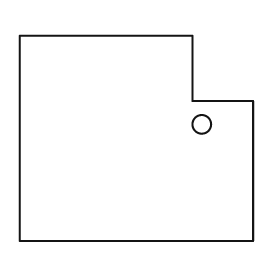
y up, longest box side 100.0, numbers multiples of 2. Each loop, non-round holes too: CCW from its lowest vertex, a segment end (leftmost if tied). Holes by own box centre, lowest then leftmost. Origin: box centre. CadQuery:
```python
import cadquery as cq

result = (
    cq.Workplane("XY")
    .moveTo(-50.0, -44.0)
    .lineTo(50.0, -44.0)
    .lineTo(50.0, 16.0)
    .lineTo(24.0, 16.0)
    .lineTo(24.0, 44.0)
    .lineTo(-50.0, 44.0)
    .close()
    .moveTo(28.0, 6.0)
    .circle(4.0)
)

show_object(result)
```